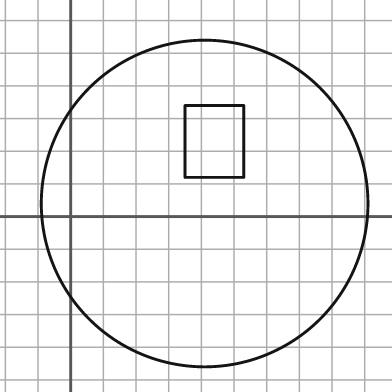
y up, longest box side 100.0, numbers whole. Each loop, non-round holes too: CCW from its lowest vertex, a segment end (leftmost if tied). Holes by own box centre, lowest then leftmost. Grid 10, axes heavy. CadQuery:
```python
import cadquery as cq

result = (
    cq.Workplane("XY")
    .moveTo(41.0, 4.0)
    .circle(50.0)
    .moveTo(35.0, 12.0)
    .lineTo(53.0, 12.0)
    .lineTo(53.0, 34.0)
    .lineTo(35.0, 34.0)
    .close()
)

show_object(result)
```